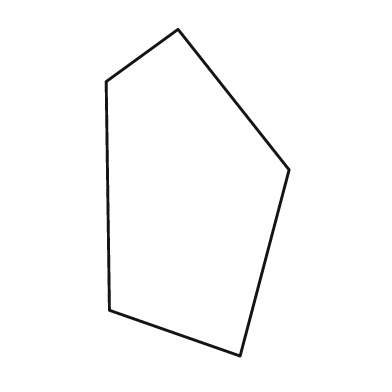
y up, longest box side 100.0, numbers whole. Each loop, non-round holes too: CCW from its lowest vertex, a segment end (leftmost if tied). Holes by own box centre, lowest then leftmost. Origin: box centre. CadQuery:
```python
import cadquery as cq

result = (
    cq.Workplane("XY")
    .moveTo(13.0, -50.0)
    .lineTo(28.0, 7.0)
    .lineTo(-6.0, 50.0)
    .lineTo(-28.0, 34.0)
    .lineTo(-27.0, -36.0)
    .close()
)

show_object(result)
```